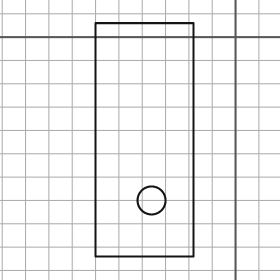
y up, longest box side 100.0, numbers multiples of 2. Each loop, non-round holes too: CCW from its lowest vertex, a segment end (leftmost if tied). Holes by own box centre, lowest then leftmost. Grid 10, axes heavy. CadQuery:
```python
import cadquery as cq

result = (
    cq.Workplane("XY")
    .moveTo(-60.0, -94.0)
    .lineTo(-18.0, -94.0)
    .lineTo(-18.0, 6.0)
    .lineTo(-60.0, 6.0)
    .close()
    .moveTo(-36.0, -70.0)
    .circle(6.0)
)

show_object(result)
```